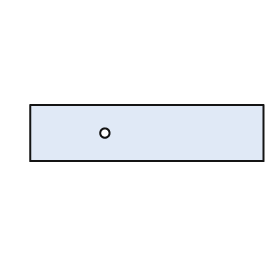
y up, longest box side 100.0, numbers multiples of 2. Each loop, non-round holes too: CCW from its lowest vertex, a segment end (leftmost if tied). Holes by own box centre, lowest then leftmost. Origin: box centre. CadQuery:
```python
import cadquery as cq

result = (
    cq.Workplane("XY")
    .moveTo(-50.0, -12.0)
    .lineTo(50.0, -12.0)
    .lineTo(50.0, 12.0)
    .lineTo(-50.0, 12.0)
    .close()
    .moveTo(-18.0, 0.0)
    .circle(2.0)
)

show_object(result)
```